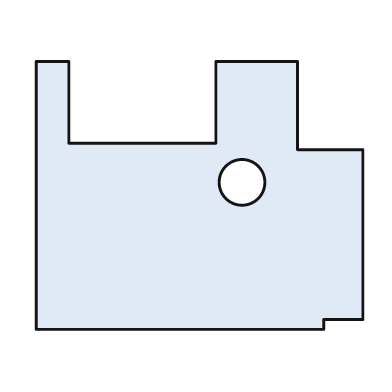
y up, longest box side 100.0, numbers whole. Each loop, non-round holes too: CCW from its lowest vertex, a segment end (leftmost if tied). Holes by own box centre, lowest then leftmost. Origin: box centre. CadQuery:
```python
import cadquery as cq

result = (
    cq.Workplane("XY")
    .moveTo(-50.0, -41.0)
    .lineTo(38.0, -41.0)
    .lineTo(38.0, -38.0)
    .lineTo(50.0, -38.0)
    .lineTo(50.0, 14.0)
    .lineTo(30.0, 14.0)
    .lineTo(30.0, 41.0)
    .lineTo(5.0, 41.0)
    .lineTo(5.0, 16.0)
    .lineTo(-40.0, 16.0)
    .lineTo(-40.0, 41.0)
    .lineTo(-50.0, 41.0)
    .close()
    .moveTo(13.0, 4.0)
    .circle(7.0)
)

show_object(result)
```